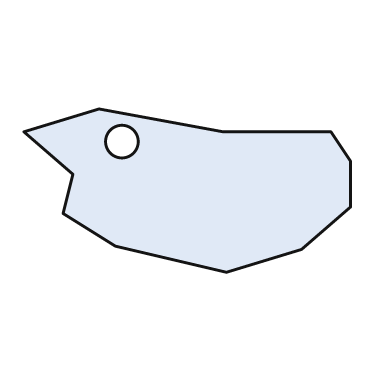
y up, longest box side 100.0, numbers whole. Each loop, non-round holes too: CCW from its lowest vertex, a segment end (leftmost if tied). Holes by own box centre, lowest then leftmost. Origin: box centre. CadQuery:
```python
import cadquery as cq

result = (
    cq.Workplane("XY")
    .moveTo(12.0, -25.0)
    .lineTo(35.0, -18.0)
    .lineTo(50.0, -5.0)
    .lineTo(50.0, 9.0)
    .lineTo(44.0, 18.0)
    .lineTo(11.0, 18.0)
    .lineTo(-27.0, 25.0)
    .lineTo(-50.0, 18.0)
    .lineTo(-35.0, 5.0)
    .lineTo(-38.0, -7.0)
    .lineTo(-22.0, -17.0)
    .close()
    .moveTo(-20.0, 15.0)
    .circle(5.0)
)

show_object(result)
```